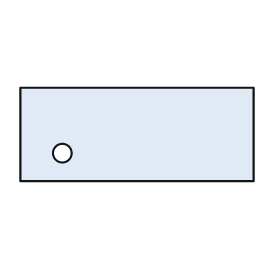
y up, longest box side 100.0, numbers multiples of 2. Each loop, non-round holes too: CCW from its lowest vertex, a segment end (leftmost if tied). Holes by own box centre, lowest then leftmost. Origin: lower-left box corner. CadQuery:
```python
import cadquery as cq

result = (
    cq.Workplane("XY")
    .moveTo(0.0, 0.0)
    .lineTo(100.0, 0.0)
    .lineTo(100.0, 40.0)
    .lineTo(0.0, 40.0)
    .close()
    .moveTo(18.0, 12.0)
    .circle(4.0)
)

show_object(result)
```